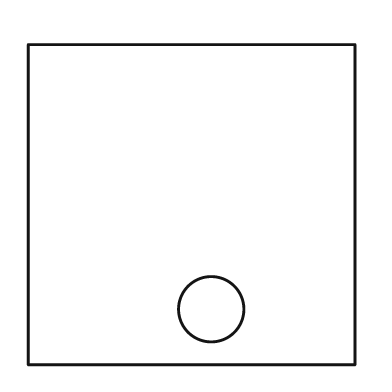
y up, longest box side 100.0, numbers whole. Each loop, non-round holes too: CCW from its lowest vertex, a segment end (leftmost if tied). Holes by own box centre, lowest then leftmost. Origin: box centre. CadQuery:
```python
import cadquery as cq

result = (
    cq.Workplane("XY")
    .moveTo(-50.0, -49.0)
    .lineTo(50.0, -49.0)
    .lineTo(50.0, 49.0)
    .lineTo(-50.0, 49.0)
    .close()
    .moveTo(6.0, -32.0)
    .circle(10.0)
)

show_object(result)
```